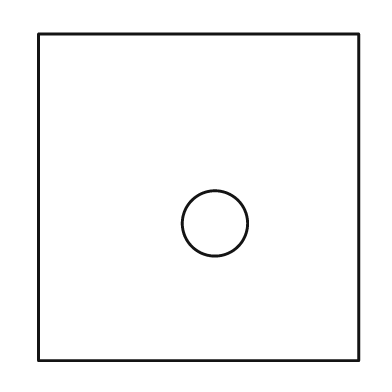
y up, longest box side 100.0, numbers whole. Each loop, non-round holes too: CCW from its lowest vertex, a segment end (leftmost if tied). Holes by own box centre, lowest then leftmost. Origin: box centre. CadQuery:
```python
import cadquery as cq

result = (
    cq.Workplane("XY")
    .moveTo(-49.0, -50.0)
    .lineTo(49.0, -50.0)
    .lineTo(49.0, 50.0)
    .lineTo(-49.0, 50.0)
    .close()
    .moveTo(5.0, -8.0)
    .circle(10.0)
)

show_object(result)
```